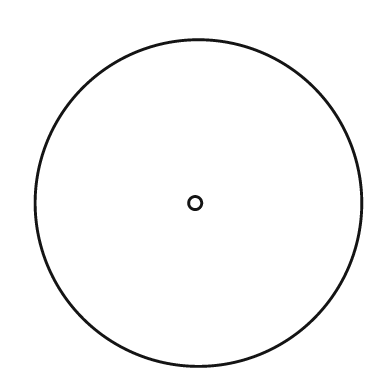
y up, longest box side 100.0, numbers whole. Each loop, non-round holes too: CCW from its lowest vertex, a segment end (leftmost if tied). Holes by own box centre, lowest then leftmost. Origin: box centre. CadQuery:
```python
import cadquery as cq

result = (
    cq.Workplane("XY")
    .moveTo(0.0, 0.0)
    .circle(50.0)
    .moveTo(-1.0, 0.0)
    .circle(2.0)
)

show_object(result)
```